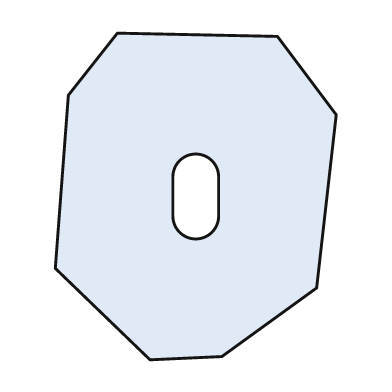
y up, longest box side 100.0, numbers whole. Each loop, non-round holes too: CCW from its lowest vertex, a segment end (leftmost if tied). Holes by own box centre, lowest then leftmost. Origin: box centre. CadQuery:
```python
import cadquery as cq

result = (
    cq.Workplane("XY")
    .moveTo(-14.0, -50.0)
    .lineTo(8.0, -49.0)
    .lineTo(37.0, -28.0)
    .lineTo(43.0, 25.0)
    .lineTo(25.0, 49.0)
    .lineTo(-24.0, 50.0)
    .lineTo(-39.0, 31.0)
    .lineTo(-43.0, -22.0)
    .close()
    .moveTo(-7.0, -6.0)
    .threePointArc((0.0, -13.0), (7.0, -6.0))
    .lineTo(7.0, 6.0)
    .threePointArc((0.0, 13.0), (-7.0, 6.0))
    .close()
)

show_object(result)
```